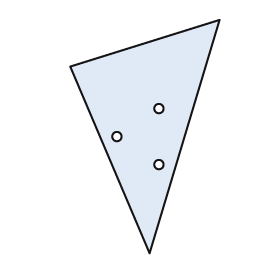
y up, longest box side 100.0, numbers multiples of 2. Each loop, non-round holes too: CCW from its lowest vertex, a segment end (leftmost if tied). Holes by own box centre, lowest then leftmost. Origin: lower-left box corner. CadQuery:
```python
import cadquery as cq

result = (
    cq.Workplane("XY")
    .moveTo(34.0, 0.0)
    .lineTo(64.0, 100.0)
    .lineTo(0.0, 80.0)
    .close()
    .moveTo(38.0, 38.0)
    .circle(2.0)
    .moveTo(20.0, 50.0)
    .circle(2.0)
    .moveTo(38.0, 62.0)
    .circle(2.0)
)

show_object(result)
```